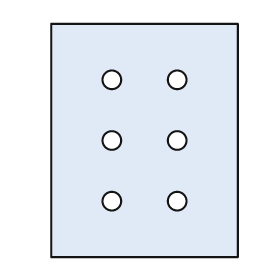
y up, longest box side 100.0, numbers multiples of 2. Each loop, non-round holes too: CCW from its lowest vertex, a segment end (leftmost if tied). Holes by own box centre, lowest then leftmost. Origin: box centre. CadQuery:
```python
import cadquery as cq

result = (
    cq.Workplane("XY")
    .moveTo(-40.0, -50.0)
    .lineTo(40.0, -50.0)
    .lineTo(40.0, 50.0)
    .lineTo(-40.0, 50.0)
    .close()
    .moveTo(-14.0, -26.0)
    .circle(4.0)
    .moveTo(14.0, -26.0)
    .circle(4.0)
    .moveTo(-14.0, 0.0)
    .circle(4.0)
    .moveTo(14.0, 0.0)
    .circle(4.0)
    .moveTo(-14.0, 26.0)
    .circle(4.0)
    .moveTo(14.0, 26.0)
    .circle(4.0)
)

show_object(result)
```